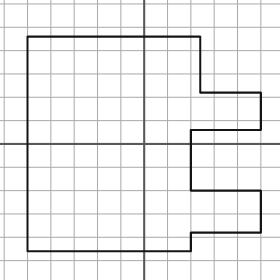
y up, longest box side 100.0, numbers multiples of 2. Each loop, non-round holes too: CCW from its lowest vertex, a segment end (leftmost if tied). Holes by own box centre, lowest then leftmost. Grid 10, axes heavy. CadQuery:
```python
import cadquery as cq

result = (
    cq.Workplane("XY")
    .moveTo(-50.0, -46.0)
    .lineTo(20.0, -46.0)
    .lineTo(20.0, -38.0)
    .lineTo(50.0, -38.0)
    .lineTo(50.0, -20.0)
    .lineTo(20.0, -20.0)
    .lineTo(20.0, 6.0)
    .lineTo(50.0, 6.0)
    .lineTo(50.0, 22.0)
    .lineTo(24.0, 22.0)
    .lineTo(24.0, 46.0)
    .lineTo(-50.0, 46.0)
    .close()
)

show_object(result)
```